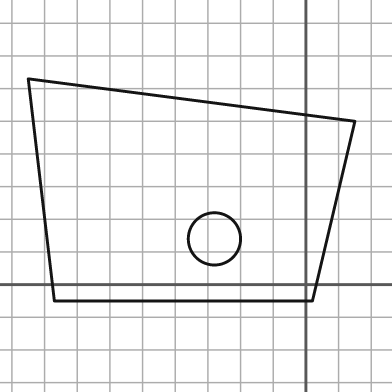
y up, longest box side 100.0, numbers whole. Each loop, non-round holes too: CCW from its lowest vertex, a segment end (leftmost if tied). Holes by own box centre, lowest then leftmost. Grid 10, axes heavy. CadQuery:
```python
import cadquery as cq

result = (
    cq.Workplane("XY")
    .moveTo(-77.0, -5.0)
    .lineTo(2.0, -5.0)
    .lineTo(15.0, 50.0)
    .lineTo(-85.0, 63.0)
    .close()
    .moveTo(-28.0, 14.0)
    .circle(8.0)
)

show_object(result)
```